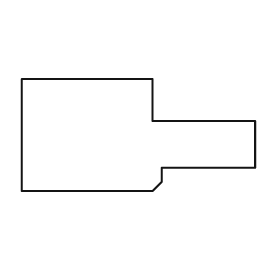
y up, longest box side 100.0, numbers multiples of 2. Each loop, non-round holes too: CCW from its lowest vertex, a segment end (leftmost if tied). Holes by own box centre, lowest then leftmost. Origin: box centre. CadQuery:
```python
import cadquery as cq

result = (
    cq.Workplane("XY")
    .moveTo(-50.0, -24.0)
    .lineTo(6.0, -24.0)
    .lineTo(10.0, -20.0)
    .lineTo(10.0, -14.0)
    .lineTo(50.0, -14.0)
    .lineTo(50.0, 6.0)
    .lineTo(6.0, 6.0)
    .lineTo(6.0, 24.0)
    .lineTo(-50.0, 24.0)
    .close()
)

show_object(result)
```